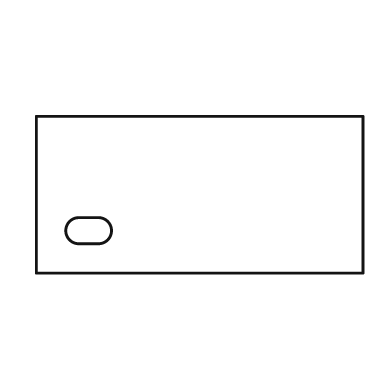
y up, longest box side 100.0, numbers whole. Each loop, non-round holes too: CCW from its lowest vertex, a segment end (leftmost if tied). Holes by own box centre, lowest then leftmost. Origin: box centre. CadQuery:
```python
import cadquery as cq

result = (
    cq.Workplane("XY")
    .moveTo(-50.0, -24.0)
    .lineTo(50.0, -24.0)
    .lineTo(50.0, 24.0)
    .lineTo(-50.0, 24.0)
    .close()
    .moveTo(-37.0, -15.0)
    .lineTo(-31.0, -15.0)
    .threePointArc((-27.0, -11.0), (-31.0, -7.0))
    .lineTo(-37.0, -7.0)
    .threePointArc((-41.0, -11.0), (-37.0, -15.0))
    .close()
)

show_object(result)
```